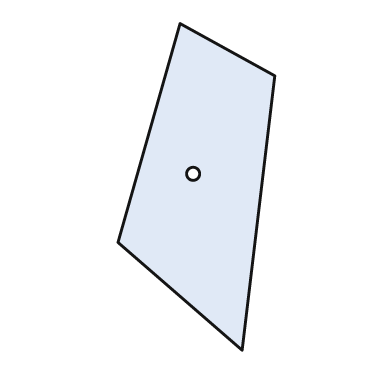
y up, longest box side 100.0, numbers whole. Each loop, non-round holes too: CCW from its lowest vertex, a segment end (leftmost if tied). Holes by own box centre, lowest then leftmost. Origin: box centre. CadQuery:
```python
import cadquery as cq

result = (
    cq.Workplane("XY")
    .moveTo(14.0, -50.0)
    .lineTo(24.0, 34.0)
    .lineTo(-5.0, 50.0)
    .lineTo(-24.0, -17.0)
    .close()
    .moveTo(-1.0, 4.0)
    .circle(2.0)
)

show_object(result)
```